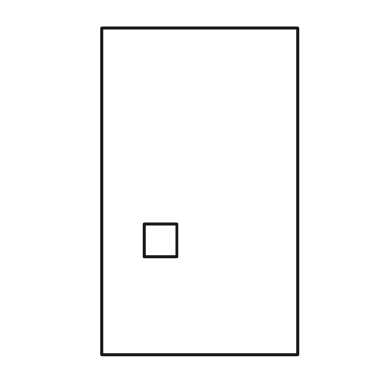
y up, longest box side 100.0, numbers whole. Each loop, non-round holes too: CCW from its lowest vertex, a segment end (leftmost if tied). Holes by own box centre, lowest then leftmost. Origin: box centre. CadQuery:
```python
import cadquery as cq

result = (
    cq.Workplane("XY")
    .moveTo(-30.0, -50.0)
    .lineTo(30.0, -50.0)
    .lineTo(30.0, 50.0)
    .lineTo(-30.0, 50.0)
    .close()
    .moveTo(-17.0, -20.0)
    .lineTo(-7.0, -20.0)
    .lineTo(-7.0, -10.0)
    .lineTo(-17.0, -10.0)
    .close()
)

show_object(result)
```